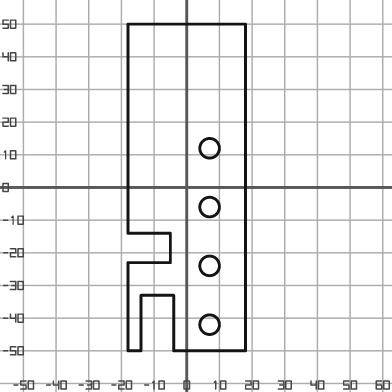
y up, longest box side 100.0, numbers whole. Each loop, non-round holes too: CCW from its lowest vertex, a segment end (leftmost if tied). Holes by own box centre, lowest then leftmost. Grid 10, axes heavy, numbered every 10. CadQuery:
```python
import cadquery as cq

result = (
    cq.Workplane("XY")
    .moveTo(-18.0, -50.0)
    .lineTo(-14.0, -50.0)
    .lineTo(-14.0, -33.0)
    .lineTo(-4.0, -33.0)
    .lineTo(-4.0, -50.0)
    .lineTo(18.0, -50.0)
    .lineTo(18.0, 50.0)
    .lineTo(-18.0, 50.0)
    .lineTo(-18.0, -14.0)
    .lineTo(-5.0, -14.0)
    .lineTo(-5.0, -23.0)
    .lineTo(-18.0, -23.0)
    .close()
    .moveTo(7.0, -42.0)
    .circle(3.0)
    .moveTo(7.0, -24.0)
    .circle(3.0)
    .moveTo(7.0, -6.0)
    .circle(3.0)
    .moveTo(7.0, 12.0)
    .circle(3.0)
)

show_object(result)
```